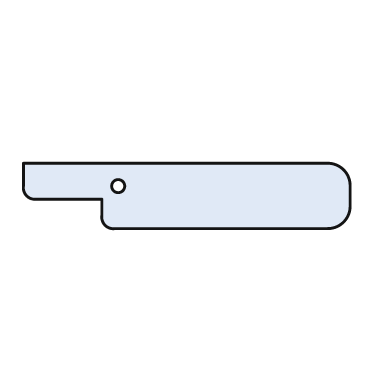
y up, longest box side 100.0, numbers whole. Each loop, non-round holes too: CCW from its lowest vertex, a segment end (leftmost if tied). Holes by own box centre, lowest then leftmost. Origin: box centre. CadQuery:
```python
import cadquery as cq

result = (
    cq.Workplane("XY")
    .moveTo(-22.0, -10.0)
    .lineTo(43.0, -10.0)
    .threePointArc((48.0, -8.0), (50.0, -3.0))
    .lineTo(50.0, 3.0)
    .threePointArc((48.0, 8.0), (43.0, 10.0))
    .lineTo(-50.0, 10.0)
    .lineTo(-50.0, 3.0)
    .threePointArc((-49.0, 0.0), (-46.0, -1.0))
    .lineTo(-26.0, -1.0)
    .lineTo(-26.0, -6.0)
    .threePointArc((-25.0, -9.0), (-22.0, -10.0))
    .close()
    .moveTo(-21.0, 3.0)
    .circle(2.0)
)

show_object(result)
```